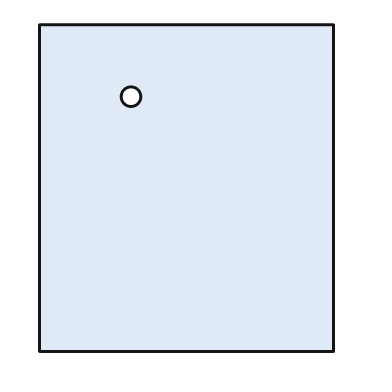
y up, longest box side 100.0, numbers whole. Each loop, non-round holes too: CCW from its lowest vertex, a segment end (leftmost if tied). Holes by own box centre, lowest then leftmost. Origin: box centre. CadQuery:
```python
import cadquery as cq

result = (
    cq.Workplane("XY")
    .moveTo(-45.0, -50.0)
    .lineTo(45.0, -50.0)
    .lineTo(45.0, 50.0)
    .lineTo(-45.0, 50.0)
    .close()
    .moveTo(-17.0, 28.0)
    .circle(3.0)
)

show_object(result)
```